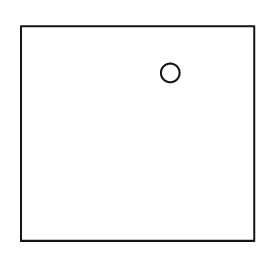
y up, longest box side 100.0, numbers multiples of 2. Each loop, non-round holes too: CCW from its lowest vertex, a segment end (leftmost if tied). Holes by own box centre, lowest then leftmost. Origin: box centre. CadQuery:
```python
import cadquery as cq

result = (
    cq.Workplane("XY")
    .moveTo(-50.0, -46.0)
    .lineTo(50.0, -46.0)
    .lineTo(50.0, 46.0)
    .lineTo(-50.0, 46.0)
    .close()
    .moveTo(14.0, 26.0)
    .circle(4.0)
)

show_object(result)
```